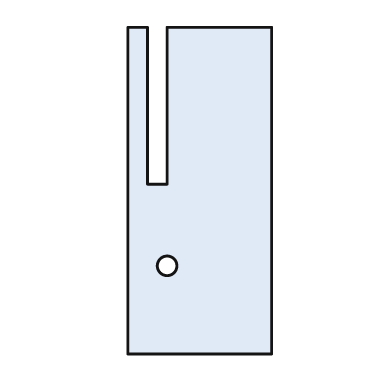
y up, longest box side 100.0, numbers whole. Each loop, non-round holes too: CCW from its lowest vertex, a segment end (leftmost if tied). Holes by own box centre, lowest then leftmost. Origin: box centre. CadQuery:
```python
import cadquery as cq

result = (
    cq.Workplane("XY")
    .moveTo(-22.0, -50.0)
    .lineTo(22.0, -50.0)
    .lineTo(22.0, 50.0)
    .lineTo(-10.0, 50.0)
    .lineTo(-10.0, 2.0)
    .lineTo(-16.0, 2.0)
    .lineTo(-16.0, 50.0)
    .lineTo(-22.0, 50.0)
    .close()
    .moveTo(-10.0, -23.0)
    .circle(3.0)
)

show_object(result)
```